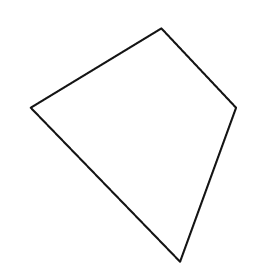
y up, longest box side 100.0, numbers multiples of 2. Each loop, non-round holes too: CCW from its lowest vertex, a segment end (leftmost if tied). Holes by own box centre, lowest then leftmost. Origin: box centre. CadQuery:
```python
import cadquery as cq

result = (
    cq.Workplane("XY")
    .moveTo(20.0, -50.0)
    .lineTo(44.0, 16.0)
    .lineTo(12.0, 50.0)
    .lineTo(-44.0, 16.0)
    .close()
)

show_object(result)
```